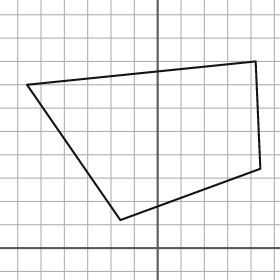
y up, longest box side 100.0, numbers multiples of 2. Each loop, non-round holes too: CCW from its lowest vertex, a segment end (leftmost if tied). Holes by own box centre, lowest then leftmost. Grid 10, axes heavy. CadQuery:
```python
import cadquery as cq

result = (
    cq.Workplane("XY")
    .moveTo(-16.0, 12.0)
    .lineTo(44.0, 34.0)
    .lineTo(42.0, 80.0)
    .lineTo(-56.0, 70.0)
    .close()
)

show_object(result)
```